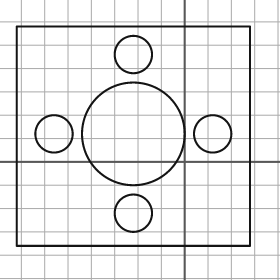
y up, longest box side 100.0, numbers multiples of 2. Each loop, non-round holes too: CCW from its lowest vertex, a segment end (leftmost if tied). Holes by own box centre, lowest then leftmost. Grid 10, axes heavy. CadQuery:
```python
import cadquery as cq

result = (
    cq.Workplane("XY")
    .moveTo(-72.0, -36.0)
    .lineTo(28.0, -36.0)
    .lineTo(28.0, 58.0)
    .lineTo(-72.0, 58.0)
    .close()
    .moveTo(-22.0, -22.0)
    .circle(8.0)
    .moveTo(-56.0, 12.0)
    .circle(8.0)
    .moveTo(-22.0, 12.0)
    .circle(22.0)
    .moveTo(12.0, 12.0)
    .circle(8.0)
    .moveTo(-22.0, 46.0)
    .circle(8.0)
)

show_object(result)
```